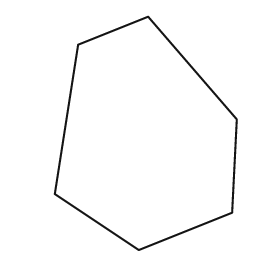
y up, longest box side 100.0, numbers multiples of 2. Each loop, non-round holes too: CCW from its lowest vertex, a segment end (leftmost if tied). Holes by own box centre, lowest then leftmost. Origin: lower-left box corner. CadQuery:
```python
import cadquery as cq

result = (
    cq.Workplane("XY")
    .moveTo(36.0, 0.0)
    .lineTo(76.0, 16.0)
    .lineTo(78.0, 56.0)
    .lineTo(40.0, 100.0)
    .lineTo(10.0, 88.0)
    .lineTo(0.0, 24.0)
    .close()
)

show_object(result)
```